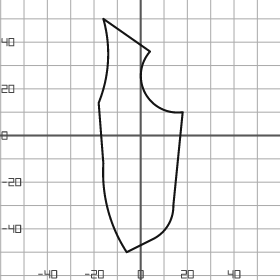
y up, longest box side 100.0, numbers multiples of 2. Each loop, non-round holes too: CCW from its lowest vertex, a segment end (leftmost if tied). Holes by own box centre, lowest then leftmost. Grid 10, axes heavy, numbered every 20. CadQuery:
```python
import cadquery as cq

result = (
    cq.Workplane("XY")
    .moveTo(-6.0, -50.0)
    .lineTo(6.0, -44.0)
    .threePointArc((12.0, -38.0), (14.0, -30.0))
    .lineTo(18.0, 10.0)
    .threePointArc((2.0, 18.0), (4.0, 36.0))
    .lineTo(-16.0, 50.0)
    .threePointArc((-14.0, 32.0), (-18.0, 14.0))
    .lineTo(-16.0, -12.0)
    .threePointArc((-14.0, -32.0), (-6.0, -50.0))
    .close()
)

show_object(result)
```